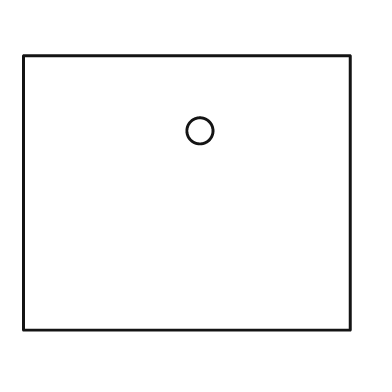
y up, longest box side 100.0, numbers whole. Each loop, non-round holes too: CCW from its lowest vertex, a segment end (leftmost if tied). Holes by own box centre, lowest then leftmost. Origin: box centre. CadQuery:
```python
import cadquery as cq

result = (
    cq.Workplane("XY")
    .moveTo(-50.0, -42.0)
    .lineTo(50.0, -42.0)
    .lineTo(50.0, 42.0)
    .lineTo(-50.0, 42.0)
    .close()
    .moveTo(4.0, 19.0)
    .circle(4.0)
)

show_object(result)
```